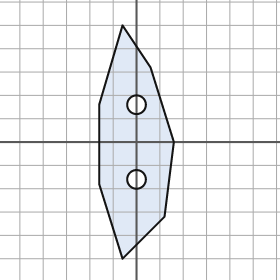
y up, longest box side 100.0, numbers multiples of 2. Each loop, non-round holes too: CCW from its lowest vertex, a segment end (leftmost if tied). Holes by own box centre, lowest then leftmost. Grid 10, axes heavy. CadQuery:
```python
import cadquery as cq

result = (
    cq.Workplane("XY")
    .moveTo(-6.0, -50.0)
    .lineTo(12.0, -32.0)
    .lineTo(16.0, 0.0)
    .lineTo(6.0, 32.0)
    .lineTo(-6.0, 50.0)
    .lineTo(-16.0, 16.0)
    .lineTo(-16.0, -18.0)
    .close()
    .moveTo(0.0, -16.0)
    .circle(4.0)
    .moveTo(0.0, 16.0)
    .circle(4.0)
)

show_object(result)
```